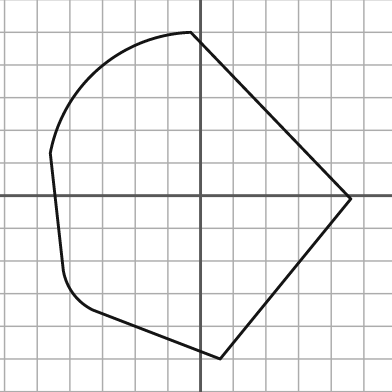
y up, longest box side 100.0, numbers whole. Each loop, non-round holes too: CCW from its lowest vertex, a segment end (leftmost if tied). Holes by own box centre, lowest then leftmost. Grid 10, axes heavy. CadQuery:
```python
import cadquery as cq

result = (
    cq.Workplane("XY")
    .moveTo(6.0, -50.0)
    .lineTo(46.0, -1.0)
    .lineTo(-3.0, 50.0)
    .threePointArc((-31.0, 39.0), (-46.0, 13.0))
    .lineTo(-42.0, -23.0)
    .threePointArc((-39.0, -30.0), (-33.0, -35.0))
    .close()
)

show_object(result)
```